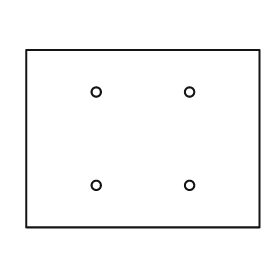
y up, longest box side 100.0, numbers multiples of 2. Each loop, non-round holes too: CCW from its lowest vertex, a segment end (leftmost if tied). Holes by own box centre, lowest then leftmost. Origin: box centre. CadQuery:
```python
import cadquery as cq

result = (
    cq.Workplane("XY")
    .moveTo(-50.0, -38.0)
    .lineTo(50.0, -38.0)
    .lineTo(50.0, 38.0)
    .lineTo(-50.0, 38.0)
    .close()
    .moveTo(-20.0, -20.0)
    .circle(2.0)
    .moveTo(20.0, -20.0)
    .circle(2.0)
    .moveTo(-20.0, 20.0)
    .circle(2.0)
    .moveTo(20.0, 20.0)
    .circle(2.0)
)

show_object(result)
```